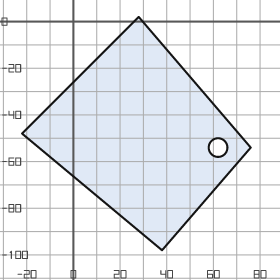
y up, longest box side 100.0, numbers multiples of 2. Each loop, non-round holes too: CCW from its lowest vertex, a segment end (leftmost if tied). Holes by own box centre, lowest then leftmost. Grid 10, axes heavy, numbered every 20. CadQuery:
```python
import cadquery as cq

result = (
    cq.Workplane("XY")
    .moveTo(38.0, -98.0)
    .lineTo(76.0, -54.0)
    .lineTo(28.0, 2.0)
    .lineTo(-22.0, -48.0)
    .close()
    .moveTo(62.0, -54.0)
    .circle(4.0)
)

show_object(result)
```